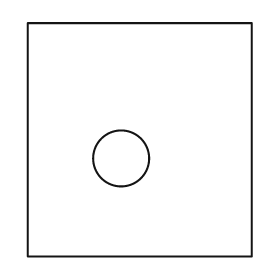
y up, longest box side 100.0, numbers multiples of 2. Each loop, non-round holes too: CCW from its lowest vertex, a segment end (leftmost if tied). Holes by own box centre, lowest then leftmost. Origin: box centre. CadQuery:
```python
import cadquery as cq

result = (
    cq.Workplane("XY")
    .moveTo(-48.0, -50.0)
    .lineTo(48.0, -50.0)
    .lineTo(48.0, 50.0)
    .lineTo(-48.0, 50.0)
    .close()
    .moveTo(-8.0, -8.0)
    .circle(12.0)
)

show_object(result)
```